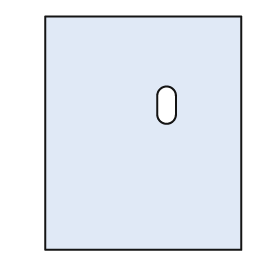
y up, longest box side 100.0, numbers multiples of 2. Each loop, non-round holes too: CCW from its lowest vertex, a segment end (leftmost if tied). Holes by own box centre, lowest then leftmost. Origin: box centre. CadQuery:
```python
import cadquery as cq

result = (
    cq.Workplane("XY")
    .moveTo(-42.0, -50.0)
    .lineTo(42.0, -50.0)
    .lineTo(42.0, 50.0)
    .lineTo(-42.0, 50.0)
    .close()
    .moveTo(6.0, 8.0)
    .threePointArc((10.0, 4.0), (14.0, 8.0))
    .lineTo(14.0, 16.0)
    .threePointArc((10.0, 20.0), (6.0, 16.0))
    .close()
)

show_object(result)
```